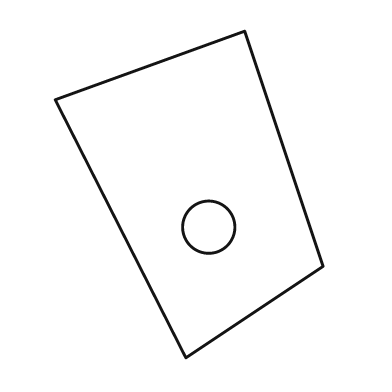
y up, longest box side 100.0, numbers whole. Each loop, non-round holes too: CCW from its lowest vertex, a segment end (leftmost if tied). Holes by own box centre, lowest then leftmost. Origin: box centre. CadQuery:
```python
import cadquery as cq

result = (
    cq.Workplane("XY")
    .moveTo(-1.0, -50.0)
    .lineTo(41.0, -22.0)
    .lineTo(17.0, 50.0)
    .lineTo(-41.0, 29.0)
    .close()
    .moveTo(6.0, -10.0)
    .circle(8.0)
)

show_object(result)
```